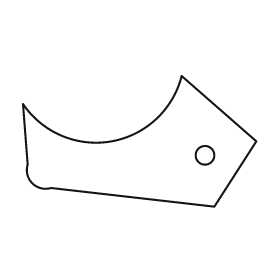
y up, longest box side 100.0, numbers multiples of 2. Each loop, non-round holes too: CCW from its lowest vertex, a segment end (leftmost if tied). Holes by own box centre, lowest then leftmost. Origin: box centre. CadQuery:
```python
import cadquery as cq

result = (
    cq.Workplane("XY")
    .moveTo(32.0, -28.0)
    .lineTo(50.0, 0.0)
    .lineTo(18.0, 28.0)
    .threePointArc((-12.0, 0.0), (-50.0, 16.0))
    .lineTo(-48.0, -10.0)
    .threePointArc((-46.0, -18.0), (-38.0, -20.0))
    .close()
    .moveTo(28.0, -6.0)
    .circle(4.0)
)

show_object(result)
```